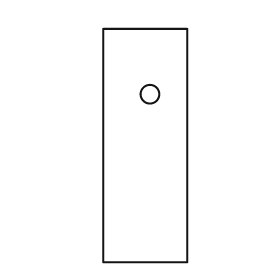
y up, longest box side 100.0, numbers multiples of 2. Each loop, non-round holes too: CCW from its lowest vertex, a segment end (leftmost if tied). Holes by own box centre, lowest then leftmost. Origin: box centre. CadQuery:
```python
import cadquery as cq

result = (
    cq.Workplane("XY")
    .moveTo(-18.0, -50.0)
    .lineTo(18.0, -50.0)
    .lineTo(18.0, 50.0)
    .lineTo(-18.0, 50.0)
    .close()
    .moveTo(2.0, 22.0)
    .circle(4.0)
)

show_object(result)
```